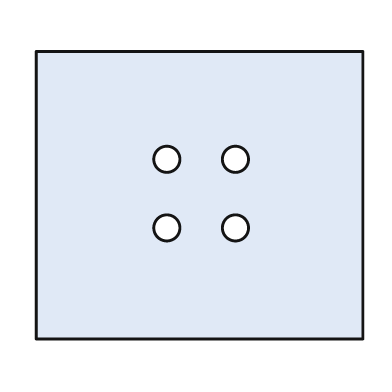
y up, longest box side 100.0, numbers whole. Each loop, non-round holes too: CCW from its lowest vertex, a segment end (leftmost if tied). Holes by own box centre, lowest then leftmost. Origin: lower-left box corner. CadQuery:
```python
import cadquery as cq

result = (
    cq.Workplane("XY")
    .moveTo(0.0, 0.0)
    .lineTo(100.0, 0.0)
    .lineTo(100.0, 88.0)
    .lineTo(0.0, 88.0)
    .close()
    .moveTo(40.0, 34.0)
    .circle(4.0)
    .moveTo(61.0, 34.0)
    .circle(4.0)
    .moveTo(40.0, 55.0)
    .circle(4.0)
    .moveTo(61.0, 55.0)
    .circle(4.0)
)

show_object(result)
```